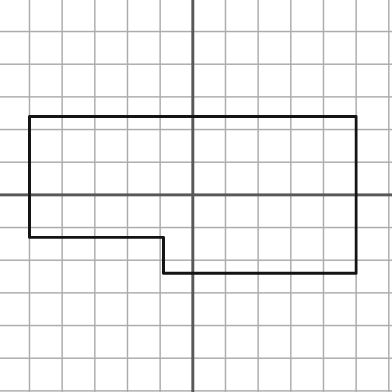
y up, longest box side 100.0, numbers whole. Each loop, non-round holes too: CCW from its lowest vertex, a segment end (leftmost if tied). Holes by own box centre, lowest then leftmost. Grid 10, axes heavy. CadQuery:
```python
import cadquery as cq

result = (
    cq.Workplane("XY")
    .moveTo(-9.0, -24.0)
    .lineTo(50.0, -24.0)
    .lineTo(50.0, 24.0)
    .lineTo(-50.0, 24.0)
    .lineTo(-50.0, -13.0)
    .lineTo(-9.0, -13.0)
    .close()
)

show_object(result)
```